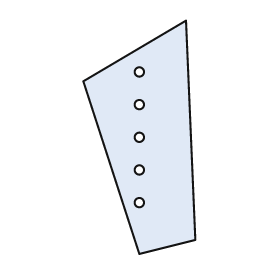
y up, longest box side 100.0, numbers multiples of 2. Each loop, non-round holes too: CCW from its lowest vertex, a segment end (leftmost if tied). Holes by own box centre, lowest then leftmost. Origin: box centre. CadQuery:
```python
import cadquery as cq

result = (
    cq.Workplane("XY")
    .moveTo(0.0, -50.0)
    .lineTo(24.0, -44.0)
    .lineTo(20.0, 50.0)
    .lineTo(-24.0, 24.0)
    .close()
    .moveTo(0.0, -28.0)
    .circle(2.0)
    .moveTo(0.0, -14.0)
    .circle(2.0)
    .moveTo(0.0, 0.0)
    .circle(2.0)
    .moveTo(0.0, 14.0)
    .circle(2.0)
    .moveTo(0.0, 28.0)
    .circle(2.0)
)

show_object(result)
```